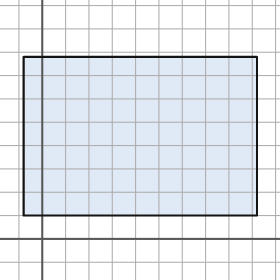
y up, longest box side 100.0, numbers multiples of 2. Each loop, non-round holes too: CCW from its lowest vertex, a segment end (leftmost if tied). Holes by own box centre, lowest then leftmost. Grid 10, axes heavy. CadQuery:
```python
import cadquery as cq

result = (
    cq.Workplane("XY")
    .moveTo(-8.0, 10.0)
    .lineTo(92.0, 10.0)
    .lineTo(92.0, 78.0)
    .lineTo(-8.0, 78.0)
    .close()
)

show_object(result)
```